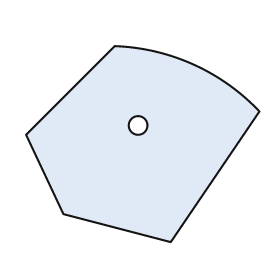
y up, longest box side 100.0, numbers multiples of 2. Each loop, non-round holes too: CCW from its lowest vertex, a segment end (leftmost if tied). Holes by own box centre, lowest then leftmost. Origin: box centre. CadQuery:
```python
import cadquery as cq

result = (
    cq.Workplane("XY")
    .moveTo(12.0, -42.0)
    .lineTo(50.0, 14.0)
    .threePointArc((22.0, 34.0), (-12.0, 42.0))
    .lineTo(-50.0, 4.0)
    .lineTo(-34.0, -30.0)
    .close()
    .moveTo(-2.0, 8.0)
    .circle(4.0)
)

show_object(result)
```